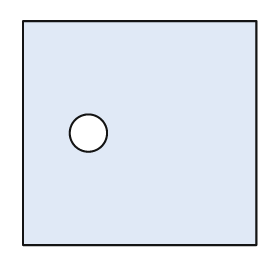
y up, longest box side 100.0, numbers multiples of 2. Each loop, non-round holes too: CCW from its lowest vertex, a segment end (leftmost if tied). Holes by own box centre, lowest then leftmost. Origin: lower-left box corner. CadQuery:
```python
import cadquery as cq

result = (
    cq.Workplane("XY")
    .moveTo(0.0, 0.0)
    .lineTo(100.0, 0.0)
    .lineTo(100.0, 96.0)
    .lineTo(0.0, 96.0)
    .close()
    .moveTo(28.0, 48.0)
    .circle(8.0)
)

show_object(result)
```